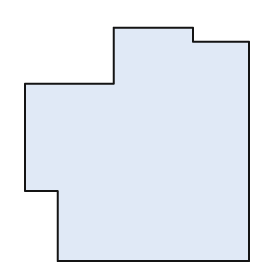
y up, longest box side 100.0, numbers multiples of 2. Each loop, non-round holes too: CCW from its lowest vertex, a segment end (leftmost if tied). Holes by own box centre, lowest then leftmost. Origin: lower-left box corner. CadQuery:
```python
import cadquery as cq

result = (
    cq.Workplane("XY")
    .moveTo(14.0, 0.0)
    .lineTo(96.0, 0.0)
    .lineTo(96.0, 94.0)
    .lineTo(72.0, 94.0)
    .lineTo(72.0, 100.0)
    .lineTo(38.0, 100.0)
    .lineTo(38.0, 76.0)
    .lineTo(0.0, 76.0)
    .lineTo(0.0, 30.0)
    .lineTo(14.0, 30.0)
    .close()
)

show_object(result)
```